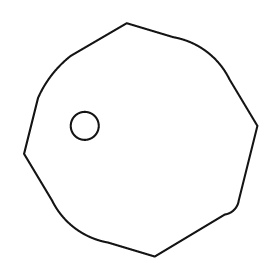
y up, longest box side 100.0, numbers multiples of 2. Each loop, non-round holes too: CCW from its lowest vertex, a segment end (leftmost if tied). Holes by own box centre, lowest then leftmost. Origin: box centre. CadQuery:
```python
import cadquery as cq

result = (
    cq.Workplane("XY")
    .moveTo(6.0, -50.0)
    .lineTo(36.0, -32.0)
    .threePointArc((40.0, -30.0), (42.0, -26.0))
    .lineTo(50.0, 6.0)
    .lineTo(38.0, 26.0)
    .threePointArc((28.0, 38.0), (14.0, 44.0))
    .lineTo(-6.0, 50.0)
    .lineTo(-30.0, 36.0)
    .threePointArc((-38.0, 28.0), (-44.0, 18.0))
    .lineTo(-50.0, -6.0)
    .lineTo(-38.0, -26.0)
    .threePointArc((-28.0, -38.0), (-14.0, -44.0))
    .close()
    .moveTo(-24.0, 6.0)
    .circle(6.0)
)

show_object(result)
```